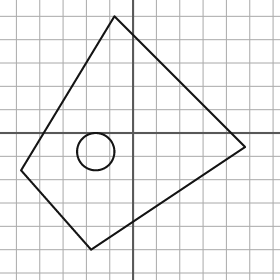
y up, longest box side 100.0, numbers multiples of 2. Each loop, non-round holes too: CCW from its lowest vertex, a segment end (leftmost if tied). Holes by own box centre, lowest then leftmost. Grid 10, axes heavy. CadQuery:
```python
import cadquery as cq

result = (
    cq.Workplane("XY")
    .moveTo(-18.0, -50.0)
    .lineTo(48.0, -6.0)
    .lineTo(-8.0, 50.0)
    .lineTo(-48.0, -16.0)
    .close()
    .moveTo(-16.0, -8.0)
    .circle(8.0)
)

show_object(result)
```